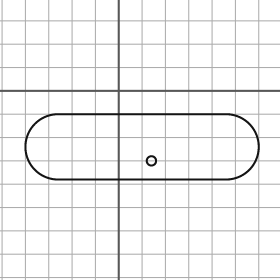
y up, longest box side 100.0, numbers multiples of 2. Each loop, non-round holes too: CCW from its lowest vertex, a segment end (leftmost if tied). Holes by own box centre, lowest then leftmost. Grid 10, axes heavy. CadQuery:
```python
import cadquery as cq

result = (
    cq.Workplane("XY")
    .moveTo(-26.0, -38.0)
    .lineTo(46.0, -38.0)
    .threePointArc((60.0, -24.0), (46.0, -10.0))
    .lineTo(-26.0, -10.0)
    .threePointArc((-40.0, -24.0), (-26.0, -38.0))
    .close()
    .moveTo(14.0, -30.0)
    .circle(2.0)
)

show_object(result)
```